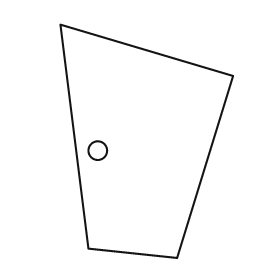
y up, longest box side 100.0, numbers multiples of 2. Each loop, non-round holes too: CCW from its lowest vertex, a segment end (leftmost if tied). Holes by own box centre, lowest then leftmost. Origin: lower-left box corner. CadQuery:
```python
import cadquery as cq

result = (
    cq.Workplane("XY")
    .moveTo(50.0, 0.0)
    .lineTo(74.0, 78.0)
    .lineTo(0.0, 100.0)
    .lineTo(12.0, 4.0)
    .close()
    .moveTo(16.0, 46.0)
    .circle(4.0)
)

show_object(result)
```